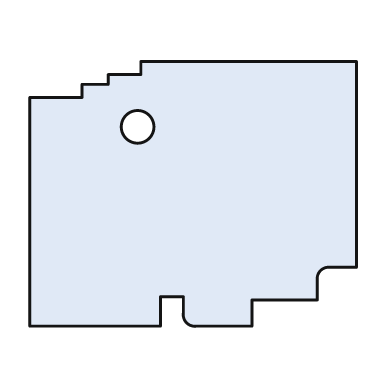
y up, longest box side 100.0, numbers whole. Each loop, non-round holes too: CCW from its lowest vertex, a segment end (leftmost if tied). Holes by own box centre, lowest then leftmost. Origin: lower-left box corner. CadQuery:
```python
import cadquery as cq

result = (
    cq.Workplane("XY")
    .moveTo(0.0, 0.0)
    .lineTo(40.0, 0.0)
    .lineTo(40.0, 9.0)
    .lineTo(47.0, 9.0)
    .lineTo(47.0, 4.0)
    .threePointArc((48.0, 1.0), (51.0, 0.0))
    .lineTo(68.0, 0.0)
    .lineTo(68.0, 8.0)
    .lineTo(88.0, 8.0)
    .lineTo(88.0, 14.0)
    .threePointArc((89.0, 17.0), (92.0, 18.0))
    .lineTo(100.0, 18.0)
    .lineTo(100.0, 81.0)
    .lineTo(34.0, 81.0)
    .lineTo(34.0, 77.0)
    .lineTo(24.0, 77.0)
    .lineTo(24.0, 74.0)
    .lineTo(16.0, 74.0)
    .lineTo(16.0, 70.0)
    .lineTo(0.0, 70.0)
    .close()
    .moveTo(33.0, 61.0)
    .circle(5.0)
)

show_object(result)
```